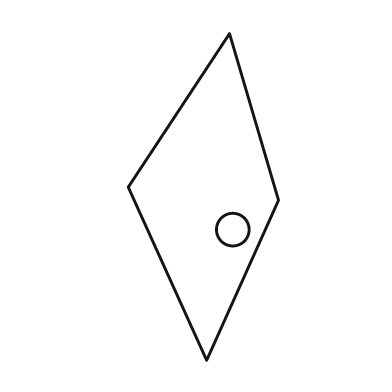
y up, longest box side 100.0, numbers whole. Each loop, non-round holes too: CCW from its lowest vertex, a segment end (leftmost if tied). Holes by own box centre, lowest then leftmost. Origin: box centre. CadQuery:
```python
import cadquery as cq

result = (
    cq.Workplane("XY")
    .moveTo(1.0, -50.0)
    .lineTo(23.0, -1.0)
    .lineTo(8.0, 50.0)
    .lineTo(-23.0, 3.0)
    .close()
    .moveTo(9.0, -10.0)
    .circle(5.0)
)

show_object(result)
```